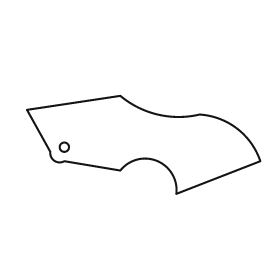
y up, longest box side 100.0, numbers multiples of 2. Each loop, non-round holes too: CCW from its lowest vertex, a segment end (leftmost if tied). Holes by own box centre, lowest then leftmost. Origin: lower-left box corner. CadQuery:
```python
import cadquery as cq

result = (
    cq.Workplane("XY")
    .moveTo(64.0, 0.0)
    .lineTo(100.0, 14.0)
    .threePointArc((90.0, 28.0), (74.0, 34.0))
    .threePointArc((56.0, 34.0), (40.0, 42.0))
    .lineTo(0.0, 36.0)
    .lineTo(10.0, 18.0)
    .threePointArc((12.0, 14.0), (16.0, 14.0))
    .lineTo(40.0, 10.0)
    .threePointArc((56.0, 14.0), (64.0, 0.0))
    .close()
    .moveTo(16.0, 20.0)
    .circle(2.0)
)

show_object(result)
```